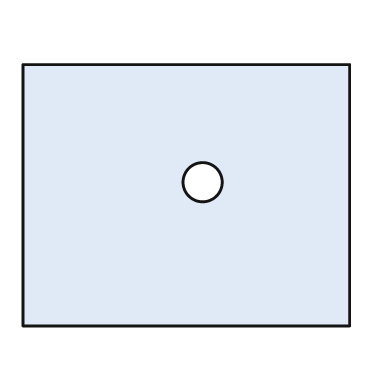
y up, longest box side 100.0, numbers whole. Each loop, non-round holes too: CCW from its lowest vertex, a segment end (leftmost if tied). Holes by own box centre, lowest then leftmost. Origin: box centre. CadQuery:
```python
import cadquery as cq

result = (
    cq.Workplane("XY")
    .moveTo(-50.0, -40.0)
    .lineTo(50.0, -40.0)
    .lineTo(50.0, 40.0)
    .lineTo(-50.0, 40.0)
    .close()
    .moveTo(5.0, 4.0)
    .circle(6.0)
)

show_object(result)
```